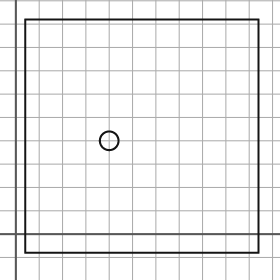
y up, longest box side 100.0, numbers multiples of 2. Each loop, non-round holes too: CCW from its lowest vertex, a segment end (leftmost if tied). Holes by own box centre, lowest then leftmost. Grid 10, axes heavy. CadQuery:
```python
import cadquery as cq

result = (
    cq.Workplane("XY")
    .moveTo(4.0, -8.0)
    .lineTo(104.0, -8.0)
    .lineTo(104.0, 92.0)
    .lineTo(4.0, 92.0)
    .close()
    .moveTo(40.0, 40.0)
    .circle(4.0)
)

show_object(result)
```